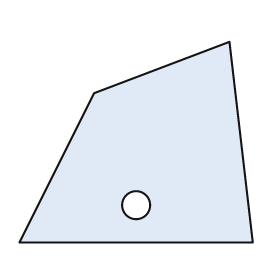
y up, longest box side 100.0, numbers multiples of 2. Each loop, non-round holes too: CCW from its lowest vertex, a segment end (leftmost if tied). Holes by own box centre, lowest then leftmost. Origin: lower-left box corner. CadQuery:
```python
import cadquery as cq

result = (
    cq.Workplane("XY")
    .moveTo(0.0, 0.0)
    .lineTo(100.0, 0.0)
    .lineTo(90.0, 86.0)
    .lineTo(32.0, 64.0)
    .close()
    .moveTo(50.0, 16.0)
    .circle(6.0)
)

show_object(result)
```